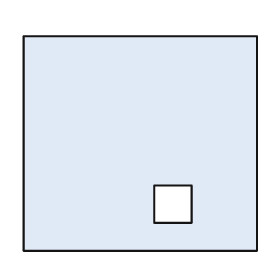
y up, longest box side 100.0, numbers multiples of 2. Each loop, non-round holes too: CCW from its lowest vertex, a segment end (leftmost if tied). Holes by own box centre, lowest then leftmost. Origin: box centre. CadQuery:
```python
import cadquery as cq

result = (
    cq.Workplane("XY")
    .moveTo(-50.0, -46.0)
    .lineTo(50.0, -46.0)
    .lineTo(50.0, 46.0)
    .lineTo(-50.0, 46.0)
    .close()
    .moveTo(6.0, -34.0)
    .lineTo(22.0, -34.0)
    .lineTo(22.0, -18.0)
    .lineTo(6.0, -18.0)
    .close()
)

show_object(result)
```